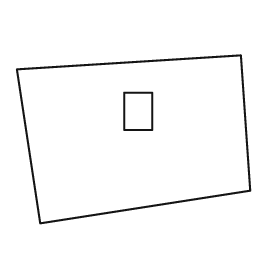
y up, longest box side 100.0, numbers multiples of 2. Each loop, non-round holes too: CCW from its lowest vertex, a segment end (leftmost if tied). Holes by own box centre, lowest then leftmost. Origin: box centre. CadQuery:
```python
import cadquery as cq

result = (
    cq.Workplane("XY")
    .moveTo(-40.0, -36.0)
    .lineTo(50.0, -22.0)
    .lineTo(46.0, 36.0)
    .lineTo(-50.0, 30.0)
    .close()
    .moveTo(-4.0, 4.0)
    .lineTo(8.0, 4.0)
    .lineTo(8.0, 20.0)
    .lineTo(-4.0, 20.0)
    .close()
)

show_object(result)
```